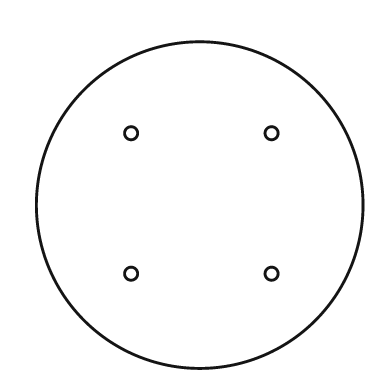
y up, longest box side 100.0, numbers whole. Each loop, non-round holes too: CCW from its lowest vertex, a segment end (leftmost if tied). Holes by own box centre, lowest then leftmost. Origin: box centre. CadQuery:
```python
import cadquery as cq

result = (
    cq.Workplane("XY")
    .moveTo(0.0, 0.0)
    .circle(50.0)
    .moveTo(-21.0, -21.0)
    .circle(2.0)
    .moveTo(22.0, -21.0)
    .circle(2.0)
    .moveTo(-21.0, 22.0)
    .circle(2.0)
    .moveTo(22.0, 22.0)
    .circle(2.0)
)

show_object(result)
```